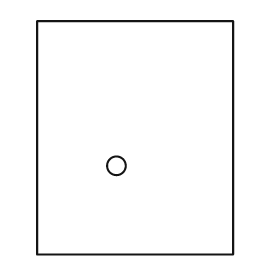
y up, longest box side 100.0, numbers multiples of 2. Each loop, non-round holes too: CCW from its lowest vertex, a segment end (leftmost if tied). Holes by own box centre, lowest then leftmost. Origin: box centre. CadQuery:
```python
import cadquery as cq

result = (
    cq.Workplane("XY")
    .moveTo(-42.0, -50.0)
    .lineTo(42.0, -50.0)
    .lineTo(42.0, 50.0)
    .lineTo(-42.0, 50.0)
    .close()
    .moveTo(-8.0, -12.0)
    .circle(4.0)
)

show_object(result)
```